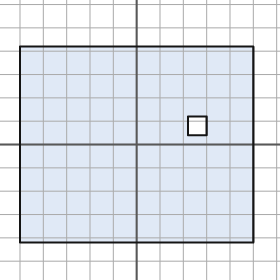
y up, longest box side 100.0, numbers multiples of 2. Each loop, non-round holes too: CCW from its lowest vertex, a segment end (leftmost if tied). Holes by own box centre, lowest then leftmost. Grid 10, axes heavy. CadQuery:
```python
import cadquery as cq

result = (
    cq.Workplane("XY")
    .moveTo(-50.0, -42.0)
    .lineTo(50.0, -42.0)
    .lineTo(50.0, 42.0)
    .lineTo(-50.0, 42.0)
    .close()
    .moveTo(22.0, 4.0)
    .lineTo(30.0, 4.0)
    .lineTo(30.0, 12.0)
    .lineTo(22.0, 12.0)
    .close()
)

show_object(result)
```